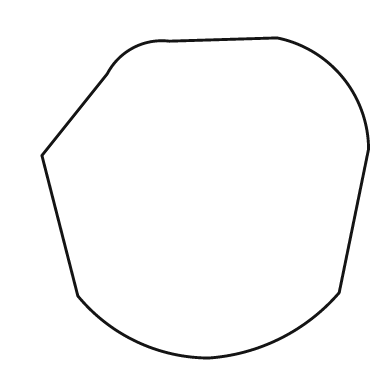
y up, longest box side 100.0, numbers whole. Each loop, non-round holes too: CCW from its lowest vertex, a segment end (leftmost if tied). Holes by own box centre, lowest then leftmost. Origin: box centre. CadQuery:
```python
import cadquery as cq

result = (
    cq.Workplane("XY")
    .moveTo(1.0, -49.0)
    .threePointArc((23.0, -43.0), (41.0, -29.0))
    .lineTo(50.0, 15.0)
    .threePointArc((42.0, 37.0), (22.0, 49.0))
    .lineTo(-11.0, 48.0)
    .threePointArc((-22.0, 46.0), (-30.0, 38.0))
    .lineTo(-50.0, 13.0)
    .lineTo(-39.0, -30.0)
    .threePointArc((-21.0, -44.0), (1.0, -49.0))
    .close()
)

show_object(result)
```